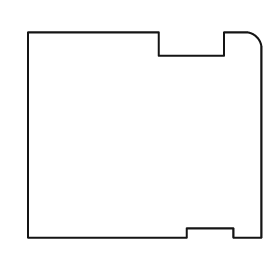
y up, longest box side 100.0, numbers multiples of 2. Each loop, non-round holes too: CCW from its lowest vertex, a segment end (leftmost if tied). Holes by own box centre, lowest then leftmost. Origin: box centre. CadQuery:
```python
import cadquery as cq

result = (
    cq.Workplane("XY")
    .moveTo(-50.0, -44.0)
    .lineTo(18.0, -44.0)
    .lineTo(18.0, -40.0)
    .lineTo(38.0, -40.0)
    .lineTo(38.0, -44.0)
    .lineTo(50.0, -44.0)
    .lineTo(50.0, 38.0)
    .threePointArc((48.0, 42.0), (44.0, 44.0))
    .lineTo(34.0, 44.0)
    .lineTo(34.0, 34.0)
    .lineTo(6.0, 34.0)
    .lineTo(6.0, 44.0)
    .lineTo(-50.0, 44.0)
    .close()
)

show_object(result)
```